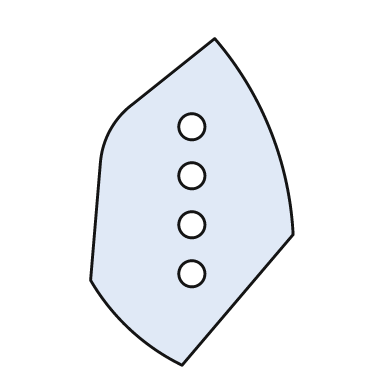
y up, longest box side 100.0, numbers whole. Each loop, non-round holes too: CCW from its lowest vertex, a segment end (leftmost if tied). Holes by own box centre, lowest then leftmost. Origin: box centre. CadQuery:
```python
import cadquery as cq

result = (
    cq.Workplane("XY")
    .moveTo(-3.0, -50.0)
    .lineTo(31.0, -10.0)
    .threePointArc((24.0, 22.0), (7.0, 50.0))
    .lineTo(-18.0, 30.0)
    .threePointArc((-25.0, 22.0), (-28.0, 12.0))
    .lineTo(-31.0, -24.0)
    .threePointArc((-19.0, -39.0), (-3.0, -50.0))
    .close()
    .moveTo(0.0, -22.0)
    .circle(4.0)
    .moveTo(0.0, -7.0)
    .circle(4.0)
    .moveTo(0.0, 8.0)
    .circle(4.0)
    .moveTo(0.0, 23.0)
    .circle(4.0)
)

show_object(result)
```